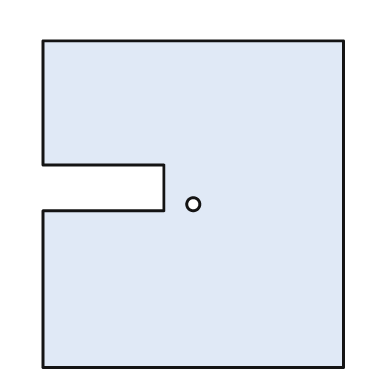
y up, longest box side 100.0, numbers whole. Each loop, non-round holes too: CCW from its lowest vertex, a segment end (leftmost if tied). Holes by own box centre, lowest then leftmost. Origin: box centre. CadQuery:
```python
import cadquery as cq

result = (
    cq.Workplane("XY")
    .moveTo(-46.0, -50.0)
    .lineTo(46.0, -50.0)
    .lineTo(46.0, 50.0)
    .lineTo(-46.0, 50.0)
    .lineTo(-46.0, 12.0)
    .lineTo(-9.0, 12.0)
    .lineTo(-9.0, -2.0)
    .lineTo(-46.0, -2.0)
    .close()
    .moveTo(0.0, 0.0)
    .circle(2.0)
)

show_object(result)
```